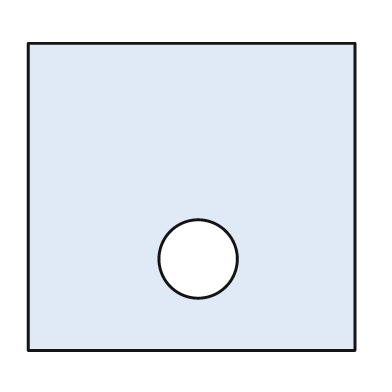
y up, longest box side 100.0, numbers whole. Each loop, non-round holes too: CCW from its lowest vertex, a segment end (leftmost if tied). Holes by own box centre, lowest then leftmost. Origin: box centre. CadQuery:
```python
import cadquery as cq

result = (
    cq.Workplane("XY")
    .moveTo(-50.0, -47.0)
    .lineTo(50.0, -47.0)
    .lineTo(50.0, 47.0)
    .lineTo(-50.0, 47.0)
    .close()
    .moveTo(2.0, -19.0)
    .circle(12.0)
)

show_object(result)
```